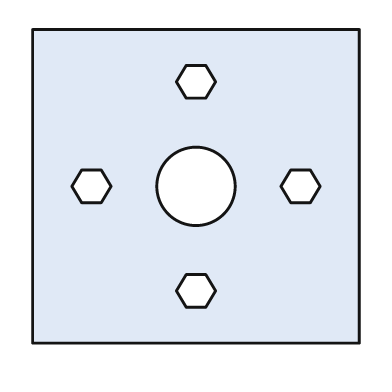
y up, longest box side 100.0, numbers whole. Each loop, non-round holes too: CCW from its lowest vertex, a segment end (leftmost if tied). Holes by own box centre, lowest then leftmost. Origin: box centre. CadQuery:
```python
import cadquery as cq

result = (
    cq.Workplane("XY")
    .moveTo(-50.0, -48.0)
    .lineTo(50.0, -48.0)
    .lineTo(50.0, 48.0)
    .lineTo(-50.0, 48.0)
    .close()
    .moveTo(-3.0, -37.0)
    .lineTo(3.0, -37.0)
    .lineTo(6.0, -32.0)
    .lineTo(3.0, -27.0)
    .lineTo(-3.0, -27.0)
    .lineTo(-6.0, -32.0)
    .close()
    .moveTo(-35.0, -5.0)
    .lineTo(-29.0, -5.0)
    .lineTo(-26.0, 0.0)
    .lineTo(-29.0, 5.0)
    .lineTo(-35.0, 5.0)
    .lineTo(-38.0, 0.0)
    .close()
    .moveTo(0.0, 0.0)
    .circle(12.0)
    .moveTo(29.0, -5.0)
    .lineTo(35.0, -5.0)
    .lineTo(38.0, 0.0)
    .lineTo(35.0, 5.0)
    .lineTo(29.0, 5.0)
    .lineTo(26.0, 0.0)
    .close()
    .moveTo(-3.0, 27.0)
    .lineTo(3.0, 27.0)
    .lineTo(6.0, 32.0)
    .lineTo(3.0, 37.0)
    .lineTo(-3.0, 37.0)
    .lineTo(-6.0, 32.0)
    .close()
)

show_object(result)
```